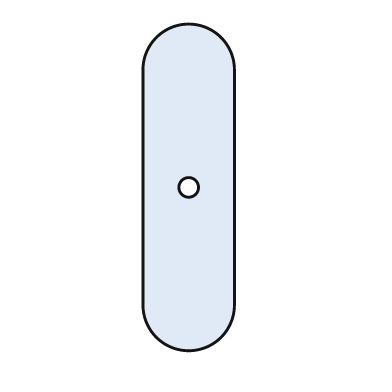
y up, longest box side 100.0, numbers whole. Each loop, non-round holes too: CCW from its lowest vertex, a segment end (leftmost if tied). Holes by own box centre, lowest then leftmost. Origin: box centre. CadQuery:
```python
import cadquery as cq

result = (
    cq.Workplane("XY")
    .moveTo(-14.0, -36.0)
    .threePointArc((0.0, -50.0), (14.0, -36.0))
    .lineTo(14.0, 36.0)
    .threePointArc((0.0, 50.0), (-14.0, 36.0))
    .close()
    .moveTo(0.0, 0.0)
    .circle(3.0)
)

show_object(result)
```